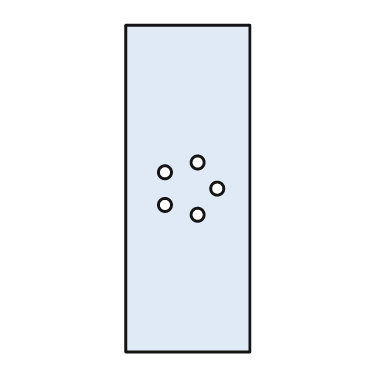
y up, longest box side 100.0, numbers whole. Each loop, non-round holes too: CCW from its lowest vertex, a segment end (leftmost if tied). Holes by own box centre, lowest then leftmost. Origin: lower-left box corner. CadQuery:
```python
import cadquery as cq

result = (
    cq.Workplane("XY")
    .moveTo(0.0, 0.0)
    .lineTo(38.0, 0.0)
    .lineTo(38.0, 100.0)
    .lineTo(0.0, 100.0)
    .close()
    .moveTo(22.0, 42.0)
    .circle(2.0)
    .moveTo(12.0, 45.0)
    .circle(2.0)
    .moveTo(28.0, 50.0)
    .circle(2.0)
    .moveTo(12.0, 55.0)
    .circle(2.0)
    .moveTo(22.0, 58.0)
    .circle(2.0)
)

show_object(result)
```